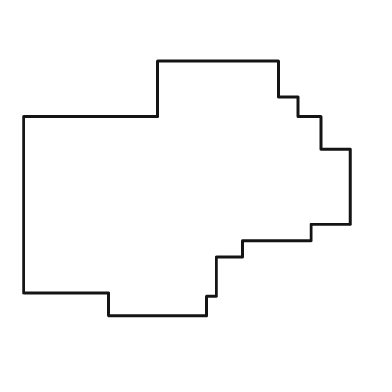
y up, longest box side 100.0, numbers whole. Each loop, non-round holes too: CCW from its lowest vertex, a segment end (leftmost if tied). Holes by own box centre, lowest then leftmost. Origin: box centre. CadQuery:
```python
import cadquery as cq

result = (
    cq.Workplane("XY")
    .moveTo(-24.0, -39.0)
    .lineTo(6.0, -39.0)
    .lineTo(6.0, -33.0)
    .lineTo(9.0, -33.0)
    .lineTo(9.0, -21.0)
    .lineTo(17.0, -21.0)
    .lineTo(17.0, -16.0)
    .lineTo(38.0, -16.0)
    .lineTo(38.0, -11.0)
    .lineTo(50.0, -11.0)
    .lineTo(50.0, 12.0)
    .lineTo(41.0, 12.0)
    .lineTo(41.0, 22.0)
    .lineTo(34.0, 22.0)
    .lineTo(34.0, 28.0)
    .lineTo(28.0, 28.0)
    .lineTo(28.0, 39.0)
    .lineTo(-9.0, 39.0)
    .lineTo(-9.0, 22.0)
    .lineTo(-50.0, 22.0)
    .lineTo(-50.0, -32.0)
    .lineTo(-24.0, -32.0)
    .close()
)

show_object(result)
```